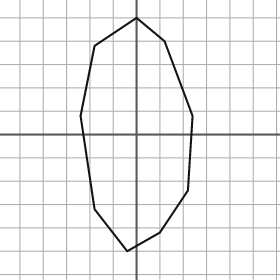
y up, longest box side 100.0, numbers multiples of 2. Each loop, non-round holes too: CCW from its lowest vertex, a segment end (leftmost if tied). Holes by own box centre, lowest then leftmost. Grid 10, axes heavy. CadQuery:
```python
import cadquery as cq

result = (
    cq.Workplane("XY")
    .moveTo(-4.0, -50.0)
    .lineTo(10.0, -42.0)
    .lineTo(22.0, -24.0)
    .lineTo(24.0, 8.0)
    .lineTo(12.0, 40.0)
    .lineTo(0.0, 50.0)
    .lineTo(-18.0, 38.0)
    .lineTo(-24.0, 8.0)
    .lineTo(-18.0, -32.0)
    .close()
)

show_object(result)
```